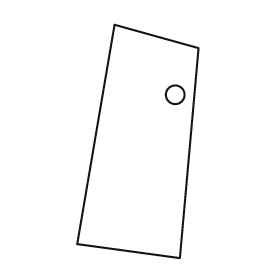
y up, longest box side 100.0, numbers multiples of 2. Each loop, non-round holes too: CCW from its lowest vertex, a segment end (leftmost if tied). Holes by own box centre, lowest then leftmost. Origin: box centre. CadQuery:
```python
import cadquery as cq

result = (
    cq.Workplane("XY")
    .moveTo(18.0, -50.0)
    .lineTo(26.0, 40.0)
    .lineTo(-10.0, 50.0)
    .lineTo(-26.0, -44.0)
    .close()
    .moveTo(16.0, 20.0)
    .circle(4.0)
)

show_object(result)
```